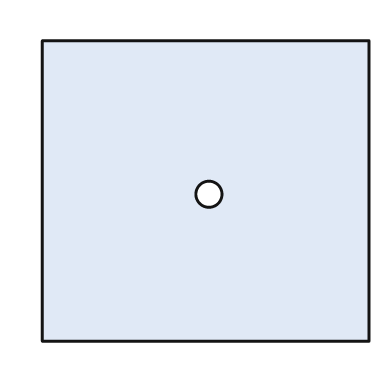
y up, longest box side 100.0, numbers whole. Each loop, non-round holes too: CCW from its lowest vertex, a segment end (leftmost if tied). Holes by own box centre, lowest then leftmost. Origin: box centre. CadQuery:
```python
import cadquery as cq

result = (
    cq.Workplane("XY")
    .moveTo(-50.0, -46.0)
    .lineTo(50.0, -46.0)
    .lineTo(50.0, 46.0)
    .lineTo(-50.0, 46.0)
    .close()
    .moveTo(1.0, -1.0)
    .circle(4.0)
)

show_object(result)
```